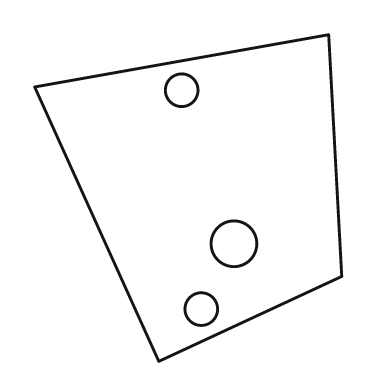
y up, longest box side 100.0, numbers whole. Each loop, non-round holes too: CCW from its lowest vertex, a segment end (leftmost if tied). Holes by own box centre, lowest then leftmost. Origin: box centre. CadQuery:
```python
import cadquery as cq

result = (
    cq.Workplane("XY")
    .moveTo(-9.0, -50.0)
    .lineTo(47.0, -24.0)
    .lineTo(43.0, 50.0)
    .lineTo(-47.0, 34.0)
    .close()
    .moveTo(4.0, -34.0)
    .circle(5.0)
    .moveTo(14.0, -14.0)
    .circle(7.0)
    .moveTo(-2.0, 33.0)
    .circle(5.0)
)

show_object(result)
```